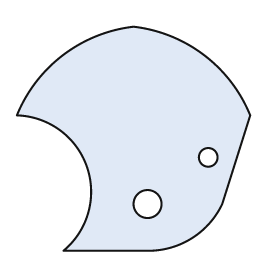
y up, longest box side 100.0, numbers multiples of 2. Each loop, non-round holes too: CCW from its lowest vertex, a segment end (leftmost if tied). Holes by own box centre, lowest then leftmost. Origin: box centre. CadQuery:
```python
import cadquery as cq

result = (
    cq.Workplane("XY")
    .moveTo(-30.0, -48.0)
    .lineTo(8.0, -48.0)
    .threePointArc((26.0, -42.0), (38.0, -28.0))
    .lineTo(50.0, 10.0)
    .threePointArc((30.0, 36.0), (0.0, 48.0))
    .threePointArc((-30.0, 36.0), (-50.0, 10.0))
    .threePointArc((-20.0, -12.0), (-30.0, -48.0))
    .close()
    .moveTo(6.0, -28.0)
    .circle(6.0)
    .moveTo(32.0, -8.0)
    .circle(4.0)
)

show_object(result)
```